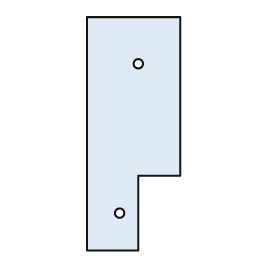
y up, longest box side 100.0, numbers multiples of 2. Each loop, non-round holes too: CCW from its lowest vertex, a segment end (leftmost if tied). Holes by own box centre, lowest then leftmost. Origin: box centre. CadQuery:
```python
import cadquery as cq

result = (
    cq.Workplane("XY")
    .moveTo(-20.0, -50.0)
    .lineTo(2.0, -50.0)
    .lineTo(2.0, -18.0)
    .lineTo(20.0, -18.0)
    .lineTo(20.0, 50.0)
    .lineTo(-20.0, 50.0)
    .close()
    .moveTo(-6.0, -34.0)
    .circle(2.0)
    .moveTo(2.0, 30.0)
    .circle(2.0)
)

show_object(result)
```